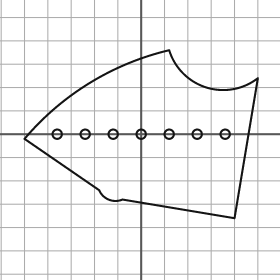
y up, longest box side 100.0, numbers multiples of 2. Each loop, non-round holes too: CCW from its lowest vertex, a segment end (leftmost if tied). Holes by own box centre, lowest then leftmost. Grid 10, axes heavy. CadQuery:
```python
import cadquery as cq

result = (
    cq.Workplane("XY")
    .moveTo(40.0, -36.0)
    .lineTo(50.0, 24.0)
    .threePointArc((28.0, 20.0), (12.0, 36.0))
    .threePointArc((-22.0, 22.0), (-50.0, -2.0))
    .lineTo(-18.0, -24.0)
    .threePointArc((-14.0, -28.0), (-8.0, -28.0))
    .close()
    .moveTo(-36.0, 0.0)
    .circle(2.0)
    .moveTo(-24.0, 0.0)
    .circle(2.0)
    .moveTo(-12.0, 0.0)
    .circle(2.0)
    .moveTo(0.0, 0.0)
    .circle(2.0)
    .moveTo(12.0, 0.0)
    .circle(2.0)
    .moveTo(24.0, 0.0)
    .circle(2.0)
    .moveTo(36.0, 0.0)
    .circle(2.0)
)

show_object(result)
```